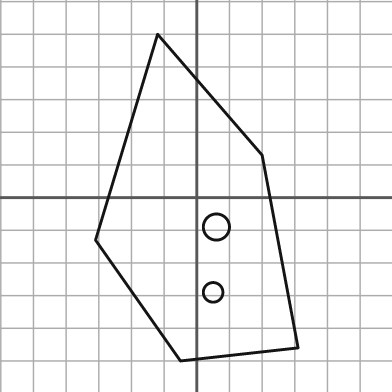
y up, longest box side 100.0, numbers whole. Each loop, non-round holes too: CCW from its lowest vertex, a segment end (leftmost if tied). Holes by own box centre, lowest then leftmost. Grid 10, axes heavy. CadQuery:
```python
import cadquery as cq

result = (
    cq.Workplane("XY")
    .moveTo(-5.0, -50.0)
    .lineTo(31.0, -46.0)
    .lineTo(20.0, 13.0)
    .lineTo(-12.0, 50.0)
    .lineTo(-31.0, -13.0)
    .close()
    .moveTo(5.0, -29.0)
    .circle(3.0)
    .moveTo(6.0, -9.0)
    .circle(4.0)
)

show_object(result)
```